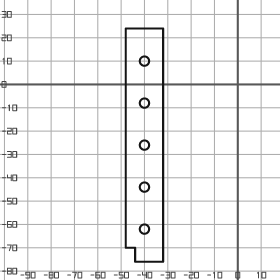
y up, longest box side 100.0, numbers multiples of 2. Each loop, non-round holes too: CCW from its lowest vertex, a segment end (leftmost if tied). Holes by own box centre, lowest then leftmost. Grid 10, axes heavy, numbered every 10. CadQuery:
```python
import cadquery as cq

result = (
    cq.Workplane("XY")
    .moveTo(-44.0, -76.0)
    .lineTo(-32.0, -76.0)
    .lineTo(-32.0, 24.0)
    .lineTo(-48.0, 24.0)
    .lineTo(-48.0, -70.0)
    .lineTo(-44.0, -70.0)
    .close()
    .moveTo(-40.0, -62.0)
    .circle(2.0)
    .moveTo(-40.0, -44.0)
    .circle(2.0)
    .moveTo(-40.0, -26.0)
    .circle(2.0)
    .moveTo(-40.0, -8.0)
    .circle(2.0)
    .moveTo(-40.0, 10.0)
    .circle(2.0)
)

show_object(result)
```